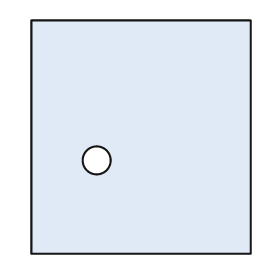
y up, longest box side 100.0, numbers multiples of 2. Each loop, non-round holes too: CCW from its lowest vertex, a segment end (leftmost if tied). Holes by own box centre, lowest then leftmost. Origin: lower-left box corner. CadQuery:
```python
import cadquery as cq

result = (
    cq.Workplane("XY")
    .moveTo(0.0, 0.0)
    .lineTo(94.0, 0.0)
    .lineTo(94.0, 100.0)
    .lineTo(0.0, 100.0)
    .close()
    .moveTo(28.0, 40.0)
    .circle(6.0)
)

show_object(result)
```